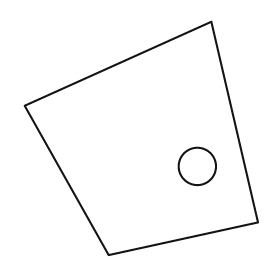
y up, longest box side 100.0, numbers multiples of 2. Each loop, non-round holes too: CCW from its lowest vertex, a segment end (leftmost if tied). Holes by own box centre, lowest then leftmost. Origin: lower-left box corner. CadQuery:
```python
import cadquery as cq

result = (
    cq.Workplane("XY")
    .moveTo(36.0, 0.0)
    .lineTo(100.0, 14.0)
    .lineTo(80.0, 100.0)
    .lineTo(0.0, 64.0)
    .close()
    .moveTo(74.0, 38.0)
    .circle(8.0)
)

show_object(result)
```